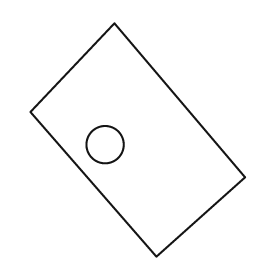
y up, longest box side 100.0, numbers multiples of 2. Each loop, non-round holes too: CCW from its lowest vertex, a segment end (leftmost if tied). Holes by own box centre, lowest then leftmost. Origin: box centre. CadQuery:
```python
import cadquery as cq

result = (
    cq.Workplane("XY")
    .moveTo(8.0, -50.0)
    .lineTo(46.0, -16.0)
    .lineTo(-10.0, 50.0)
    .lineTo(-46.0, 12.0)
    .close()
    .moveTo(-14.0, -2.0)
    .circle(8.0)
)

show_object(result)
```